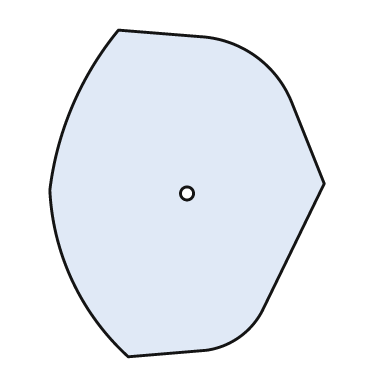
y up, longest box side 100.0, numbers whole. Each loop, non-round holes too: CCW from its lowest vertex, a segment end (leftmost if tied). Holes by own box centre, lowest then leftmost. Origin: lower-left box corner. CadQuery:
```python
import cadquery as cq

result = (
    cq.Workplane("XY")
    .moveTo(24.0, 0.0)
    .lineTo(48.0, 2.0)
    .threePointArc((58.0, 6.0), (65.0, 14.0))
    .lineTo(84.0, 53.0)
    .lineTo(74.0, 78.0)
    .threePointArc((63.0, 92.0), (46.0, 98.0))
    .lineTo(21.0, 100.0)
    .threePointArc((7.0, 77.0), (0.0, 51.0))
    .threePointArc((7.0, 23.0), (24.0, 0.0))
    .close()
    .moveTo(42.0, 50.0)
    .circle(2.0)
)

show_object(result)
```